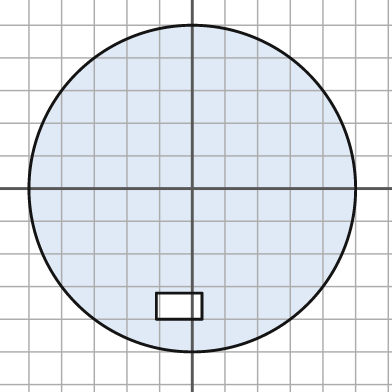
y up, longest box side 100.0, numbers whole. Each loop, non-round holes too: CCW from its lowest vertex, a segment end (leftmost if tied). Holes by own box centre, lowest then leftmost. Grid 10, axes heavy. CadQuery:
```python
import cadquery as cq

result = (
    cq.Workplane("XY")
    .moveTo(0.0, 0.0)
    .circle(50.0)
    .moveTo(-11.0, -40.0)
    .lineTo(3.0, -40.0)
    .lineTo(3.0, -32.0)
    .lineTo(-11.0, -32.0)
    .close()
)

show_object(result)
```